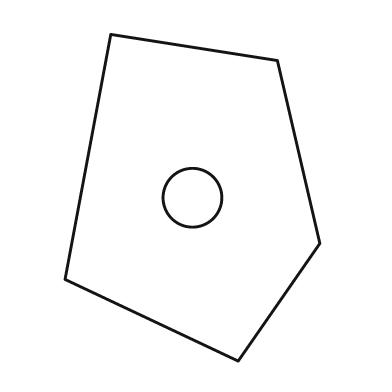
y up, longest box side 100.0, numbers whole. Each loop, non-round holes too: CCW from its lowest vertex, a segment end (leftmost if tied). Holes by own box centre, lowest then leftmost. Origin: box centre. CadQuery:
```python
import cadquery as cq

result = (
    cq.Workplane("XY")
    .moveTo(14.0, -50.0)
    .lineTo(39.0, -14.0)
    .lineTo(26.0, 42.0)
    .lineTo(-25.0, 50.0)
    .lineTo(-39.0, -25.0)
    .close()
    .moveTo(0.0, 0.0)
    .circle(9.0)
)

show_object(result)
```